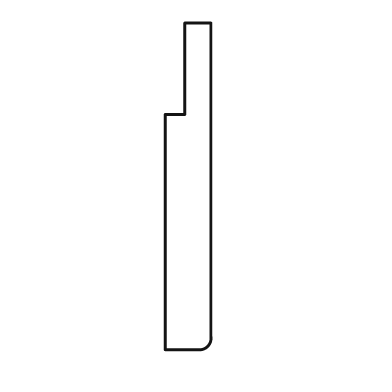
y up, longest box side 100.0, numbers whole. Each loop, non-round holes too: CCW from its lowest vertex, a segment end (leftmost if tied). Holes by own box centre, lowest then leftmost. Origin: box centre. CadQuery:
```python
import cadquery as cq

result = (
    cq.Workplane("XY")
    .moveTo(-7.0, -50.0)
    .lineTo(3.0, -50.0)
    .threePointArc((6.0, -49.0), (7.0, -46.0))
    .lineTo(7.0, 50.0)
    .lineTo(-1.0, 50.0)
    .lineTo(-1.0, 22.0)
    .lineTo(-7.0, 22.0)
    .close()
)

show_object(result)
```